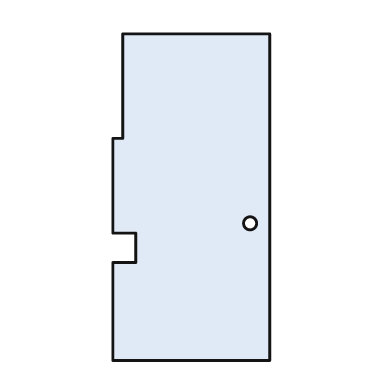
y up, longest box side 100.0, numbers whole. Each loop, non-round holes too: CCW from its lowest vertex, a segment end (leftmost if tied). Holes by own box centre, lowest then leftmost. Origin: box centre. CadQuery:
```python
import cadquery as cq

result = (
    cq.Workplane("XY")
    .moveTo(-24.0, -50.0)
    .lineTo(24.0, -50.0)
    .lineTo(24.0, 50.0)
    .lineTo(-21.0, 50.0)
    .lineTo(-21.0, 18.0)
    .lineTo(-24.0, 18.0)
    .lineTo(-24.0, -11.0)
    .lineTo(-17.0, -11.0)
    .lineTo(-17.0, -20.0)
    .lineTo(-24.0, -20.0)
    .close()
    .moveTo(18.0, -8.0)
    .circle(2.0)
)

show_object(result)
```